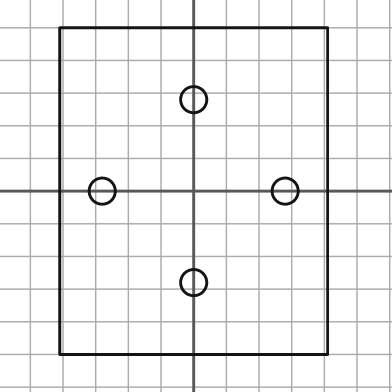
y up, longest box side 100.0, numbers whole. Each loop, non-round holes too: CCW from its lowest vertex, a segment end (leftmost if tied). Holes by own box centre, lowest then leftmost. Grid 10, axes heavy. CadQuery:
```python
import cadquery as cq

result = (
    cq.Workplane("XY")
    .moveTo(-41.0, -50.0)
    .lineTo(41.0, -50.0)
    .lineTo(41.0, 50.0)
    .lineTo(-41.0, 50.0)
    .close()
    .moveTo(0.0, -28.0)
    .circle(4.0)
    .moveTo(-28.0, 0.0)
    .circle(4.0)
    .moveTo(28.0, 0.0)
    .circle(4.0)
    .moveTo(0.0, 28.0)
    .circle(4.0)
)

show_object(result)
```